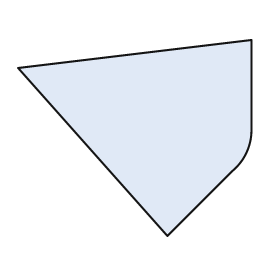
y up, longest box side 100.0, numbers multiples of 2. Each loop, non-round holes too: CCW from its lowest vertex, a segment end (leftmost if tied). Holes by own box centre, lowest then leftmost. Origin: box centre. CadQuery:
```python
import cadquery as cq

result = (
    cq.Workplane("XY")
    .moveTo(14.0, -42.0)
    .lineTo(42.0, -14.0)
    .threePointArc((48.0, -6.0), (50.0, 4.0))
    .lineTo(50.0, 42.0)
    .lineTo(-50.0, 30.0)
    .close()
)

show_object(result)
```